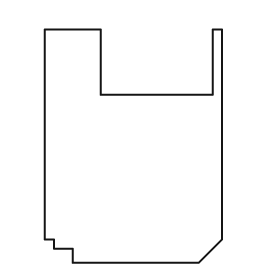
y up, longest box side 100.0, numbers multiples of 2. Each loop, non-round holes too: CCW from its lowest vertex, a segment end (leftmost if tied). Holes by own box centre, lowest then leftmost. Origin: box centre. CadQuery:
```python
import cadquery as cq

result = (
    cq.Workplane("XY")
    .moveTo(-26.0, -50.0)
    .lineTo(28.0, -50.0)
    .lineTo(38.0, -40.0)
    .lineTo(38.0, 50.0)
    .lineTo(34.0, 50.0)
    .lineTo(34.0, 22.0)
    .lineTo(-14.0, 22.0)
    .lineTo(-14.0, 50.0)
    .lineTo(-38.0, 50.0)
    .lineTo(-38.0, -40.0)
    .lineTo(-34.0, -40.0)
    .lineTo(-34.0, -44.0)
    .lineTo(-26.0, -44.0)
    .close()
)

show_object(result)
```